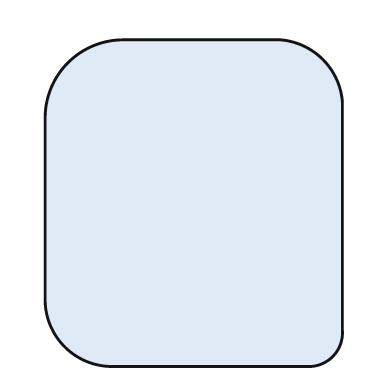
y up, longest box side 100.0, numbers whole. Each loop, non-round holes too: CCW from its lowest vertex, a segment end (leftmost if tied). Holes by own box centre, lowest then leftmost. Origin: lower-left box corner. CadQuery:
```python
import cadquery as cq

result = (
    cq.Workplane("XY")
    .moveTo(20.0, 0.0)
    .lineTo(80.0, 0.0)
    .threePointArc((88.0, 3.0), (91.0, 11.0))
    .lineTo(91.0, 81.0)
    .threePointArc((85.0, 94.0), (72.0, 100.0))
    .lineTo(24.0, 100.0)
    .threePointArc((7.0, 93.0), (0.0, 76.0))
    .lineTo(0.0, 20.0)
    .threePointArc((6.0, 6.0), (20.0, 0.0))
    .close()
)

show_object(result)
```